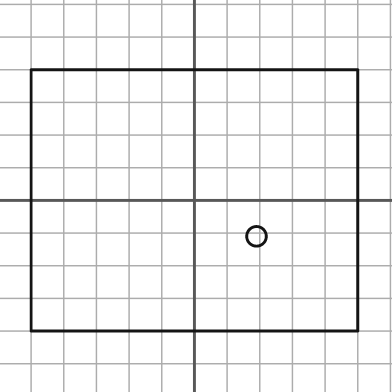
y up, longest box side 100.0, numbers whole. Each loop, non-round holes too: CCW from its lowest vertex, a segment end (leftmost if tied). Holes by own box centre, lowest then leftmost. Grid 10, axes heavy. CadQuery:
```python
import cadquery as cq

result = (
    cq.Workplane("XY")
    .moveTo(-50.0, -40.0)
    .lineTo(50.0, -40.0)
    .lineTo(50.0, 40.0)
    .lineTo(-50.0, 40.0)
    .close()
    .moveTo(19.0, -11.0)
    .circle(3.0)
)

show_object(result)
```